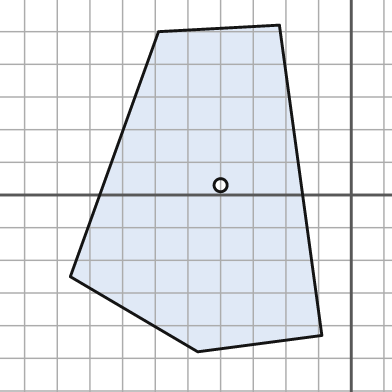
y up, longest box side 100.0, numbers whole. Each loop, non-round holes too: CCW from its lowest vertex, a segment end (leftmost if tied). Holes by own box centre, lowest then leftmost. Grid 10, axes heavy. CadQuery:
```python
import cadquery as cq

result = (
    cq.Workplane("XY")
    .moveTo(-47.0, -48.0)
    .lineTo(-9.0, -43.0)
    .lineTo(-22.0, 52.0)
    .lineTo(-59.0, 50.0)
    .lineTo(-86.0, -25.0)
    .close()
    .moveTo(-40.0, 3.0)
    .circle(2.0)
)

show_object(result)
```